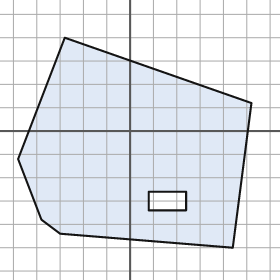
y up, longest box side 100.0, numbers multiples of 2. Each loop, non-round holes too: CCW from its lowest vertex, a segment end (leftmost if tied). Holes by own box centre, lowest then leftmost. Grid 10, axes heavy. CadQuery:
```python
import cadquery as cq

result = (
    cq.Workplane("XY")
    .moveTo(44.0, -50.0)
    .lineTo(52.0, 12.0)
    .lineTo(-28.0, 40.0)
    .lineTo(-48.0, -12.0)
    .lineTo(-38.0, -38.0)
    .lineTo(-30.0, -44.0)
    .close()
    .moveTo(8.0, -34.0)
    .lineTo(24.0, -34.0)
    .lineTo(24.0, -26.0)
    .lineTo(8.0, -26.0)
    .close()
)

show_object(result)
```